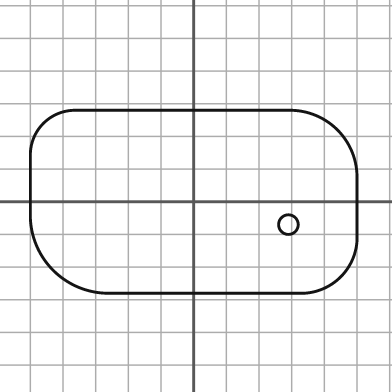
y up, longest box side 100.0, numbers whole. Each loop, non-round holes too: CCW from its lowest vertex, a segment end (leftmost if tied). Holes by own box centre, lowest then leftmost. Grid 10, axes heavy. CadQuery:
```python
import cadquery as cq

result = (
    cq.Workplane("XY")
    .moveTo(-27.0, -28.0)
    .lineTo(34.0, -28.0)
    .threePointArc((45.0, -23.0), (50.0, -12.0))
    .lineTo(50.0, 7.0)
    .threePointArc((44.0, 22.0), (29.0, 28.0))
    .lineTo(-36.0, 28.0)
    .threePointArc((-46.0, 24.0), (-50.0, 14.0))
    .lineTo(-50.0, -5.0)
    .threePointArc((-43.0, -21.0), (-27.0, -28.0))
    .close()
    .moveTo(29.0, -7.0)
    .circle(3.0)
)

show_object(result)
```